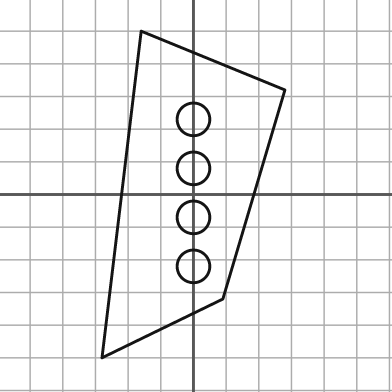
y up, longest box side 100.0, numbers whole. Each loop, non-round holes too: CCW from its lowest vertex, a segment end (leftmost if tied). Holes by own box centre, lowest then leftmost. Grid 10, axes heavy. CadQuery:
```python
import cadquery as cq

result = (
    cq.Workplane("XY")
    .moveTo(-28.0, -50.0)
    .lineTo(9.0, -32.0)
    .lineTo(28.0, 32.0)
    .lineTo(-16.0, 50.0)
    .close()
    .moveTo(0.0, -22.0)
    .circle(5.0)
    .moveTo(0.0, -7.0)
    .circle(5.0)
    .moveTo(0.0, 8.0)
    .circle(5.0)
    .moveTo(0.0, 23.0)
    .circle(5.0)
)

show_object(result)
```